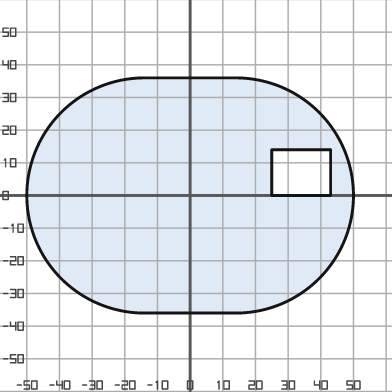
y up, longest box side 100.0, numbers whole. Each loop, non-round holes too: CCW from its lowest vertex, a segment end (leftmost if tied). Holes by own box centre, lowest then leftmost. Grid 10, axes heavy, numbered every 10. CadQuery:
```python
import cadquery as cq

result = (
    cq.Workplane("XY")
    .moveTo(-14.0, -36.0)
    .lineTo(14.0, -36.0)
    .threePointArc((50.0, 0.0), (14.0, 36.0))
    .lineTo(-14.0, 36.0)
    .threePointArc((-50.0, 0.0), (-14.0, -36.0))
    .close()
    .moveTo(25.0, 0.0)
    .lineTo(43.0, 0.0)
    .lineTo(43.0, 14.0)
    .lineTo(25.0, 14.0)
    .close()
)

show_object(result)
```